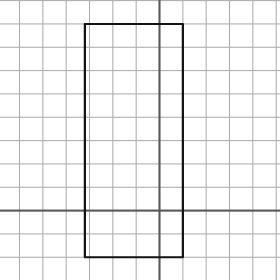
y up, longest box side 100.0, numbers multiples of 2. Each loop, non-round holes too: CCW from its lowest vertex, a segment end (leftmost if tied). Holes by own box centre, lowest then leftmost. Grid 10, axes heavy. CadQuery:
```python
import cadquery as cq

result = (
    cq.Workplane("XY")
    .moveTo(-32.0, -20.0)
    .lineTo(10.0, -20.0)
    .lineTo(10.0, 80.0)
    .lineTo(-32.0, 80.0)
    .close()
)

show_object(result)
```